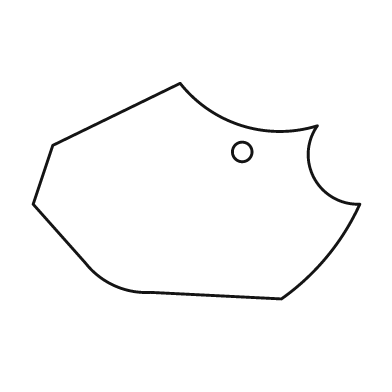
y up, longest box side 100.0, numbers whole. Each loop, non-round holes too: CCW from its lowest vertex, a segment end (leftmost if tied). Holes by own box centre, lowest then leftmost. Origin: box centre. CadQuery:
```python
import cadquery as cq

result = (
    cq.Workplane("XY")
    .moveTo(26.0, -33.0)
    .threePointArc((40.0, -20.0), (50.0, -4.0))
    .threePointArc((36.0, 4.0), (37.0, 20.0))
    .threePointArc((14.0, 20.0), (-5.0, 33.0))
    .lineTo(-44.0, 14.0)
    .lineTo(-50.0, -4.0)
    .lineTo(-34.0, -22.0)
    .threePointArc((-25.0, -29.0), (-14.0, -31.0))
    .close()
    .moveTo(14.0, 12.0)
    .circle(3.0)
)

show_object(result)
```